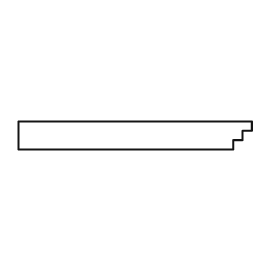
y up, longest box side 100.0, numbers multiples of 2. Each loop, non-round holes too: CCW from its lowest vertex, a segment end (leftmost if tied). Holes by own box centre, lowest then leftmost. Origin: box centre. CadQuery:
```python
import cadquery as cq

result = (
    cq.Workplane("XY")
    .moveTo(-50.0, -6.0)
    .lineTo(42.0, -6.0)
    .lineTo(42.0, -2.0)
    .lineTo(46.0, -2.0)
    .lineTo(46.0, 2.0)
    .lineTo(50.0, 2.0)
    .lineTo(50.0, 6.0)
    .lineTo(-50.0, 6.0)
    .close()
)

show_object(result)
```